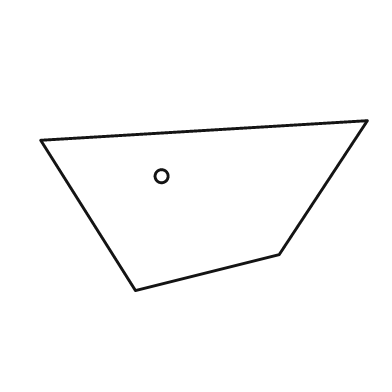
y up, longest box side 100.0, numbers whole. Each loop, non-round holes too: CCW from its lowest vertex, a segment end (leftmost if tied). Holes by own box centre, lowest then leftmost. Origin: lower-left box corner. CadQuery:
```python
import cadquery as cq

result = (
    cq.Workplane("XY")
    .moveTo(29.0, 0.0)
    .lineTo(73.0, 11.0)
    .lineTo(100.0, 52.0)
    .lineTo(0.0, 46.0)
    .close()
    .moveTo(37.0, 35.0)
    .circle(2.0)
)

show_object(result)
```